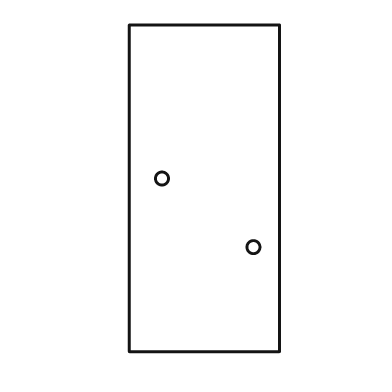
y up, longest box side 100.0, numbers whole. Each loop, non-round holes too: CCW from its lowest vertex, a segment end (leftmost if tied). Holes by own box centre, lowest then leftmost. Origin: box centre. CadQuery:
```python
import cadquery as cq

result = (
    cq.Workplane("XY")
    .moveTo(-23.0, -50.0)
    .lineTo(23.0, -50.0)
    .lineTo(23.0, 50.0)
    .lineTo(-23.0, 50.0)
    .close()
    .moveTo(15.0, -18.0)
    .circle(2.0)
    .moveTo(-13.0, 3.0)
    .circle(2.0)
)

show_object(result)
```